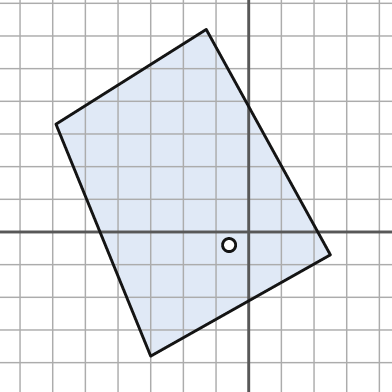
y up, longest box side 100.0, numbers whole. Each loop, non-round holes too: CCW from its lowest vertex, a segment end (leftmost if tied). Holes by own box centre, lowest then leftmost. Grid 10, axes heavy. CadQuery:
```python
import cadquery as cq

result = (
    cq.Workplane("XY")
    .moveTo(-30.0, -38.0)
    .lineTo(25.0, -7.0)
    .lineTo(-13.0, 62.0)
    .lineTo(-59.0, 33.0)
    .close()
    .moveTo(-6.0, -4.0)
    .circle(2.0)
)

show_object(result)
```